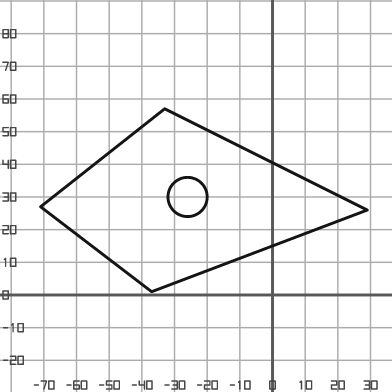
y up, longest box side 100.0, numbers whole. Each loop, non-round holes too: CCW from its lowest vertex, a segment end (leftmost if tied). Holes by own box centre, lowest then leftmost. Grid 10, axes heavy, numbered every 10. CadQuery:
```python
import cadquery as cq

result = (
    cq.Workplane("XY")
    .moveTo(-37.0, 1.0)
    .lineTo(29.0, 26.0)
    .lineTo(-33.0, 57.0)
    .lineTo(-71.0, 27.0)
    .close()
    .moveTo(-26.0, 30.0)
    .circle(6.0)
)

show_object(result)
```